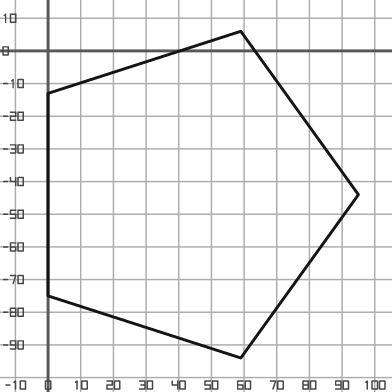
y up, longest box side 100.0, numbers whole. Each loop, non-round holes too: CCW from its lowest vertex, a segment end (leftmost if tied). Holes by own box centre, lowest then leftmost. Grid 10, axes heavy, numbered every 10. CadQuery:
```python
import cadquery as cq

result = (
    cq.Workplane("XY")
    .moveTo(59.0, -94.0)
    .lineTo(95.0, -44.0)
    .lineTo(59.0, 6.0)
    .lineTo(0.0, -13.0)
    .lineTo(0.0, -75.0)
    .close()
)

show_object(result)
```